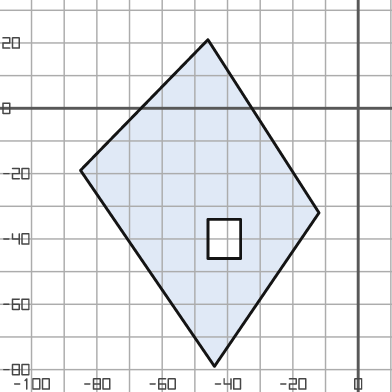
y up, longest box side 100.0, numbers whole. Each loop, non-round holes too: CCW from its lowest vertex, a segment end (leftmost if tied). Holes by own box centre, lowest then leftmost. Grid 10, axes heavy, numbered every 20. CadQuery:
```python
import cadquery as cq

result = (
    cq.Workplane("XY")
    .moveTo(-44.0, -79.0)
    .lineTo(-12.0, -32.0)
    .lineTo(-46.0, 21.0)
    .lineTo(-85.0, -19.0)
    .close()
    .moveTo(-46.0, -46.0)
    .lineTo(-36.0, -46.0)
    .lineTo(-36.0, -34.0)
    .lineTo(-46.0, -34.0)
    .close()
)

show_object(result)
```